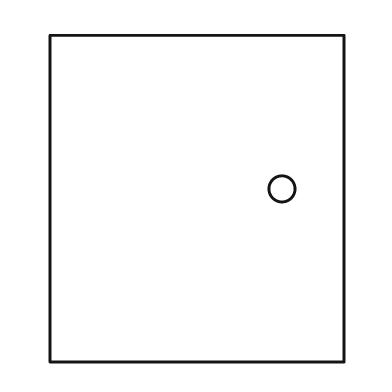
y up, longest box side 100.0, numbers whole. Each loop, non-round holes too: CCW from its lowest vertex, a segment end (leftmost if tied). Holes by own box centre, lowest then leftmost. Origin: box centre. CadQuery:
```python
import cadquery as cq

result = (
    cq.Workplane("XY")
    .moveTo(-45.0, -50.0)
    .lineTo(45.0, -50.0)
    .lineTo(45.0, 50.0)
    .lineTo(-45.0, 50.0)
    .close()
    .moveTo(26.0, 3.0)
    .circle(4.0)
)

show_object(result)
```